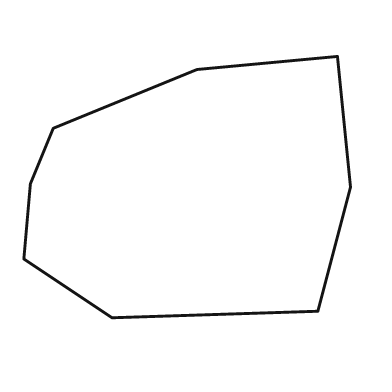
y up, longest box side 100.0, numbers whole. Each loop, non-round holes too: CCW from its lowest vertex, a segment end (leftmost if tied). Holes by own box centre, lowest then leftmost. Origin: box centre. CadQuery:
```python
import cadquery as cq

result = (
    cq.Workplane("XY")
    .moveTo(-23.0, -40.0)
    .lineTo(40.0, -38.0)
    .lineTo(50.0, 0.0)
    .lineTo(46.0, 40.0)
    .lineTo(3.0, 36.0)
    .lineTo(-41.0, 18.0)
    .lineTo(-48.0, 1.0)
    .lineTo(-50.0, -22.0)
    .close()
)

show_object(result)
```